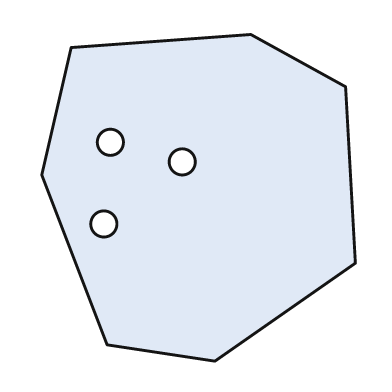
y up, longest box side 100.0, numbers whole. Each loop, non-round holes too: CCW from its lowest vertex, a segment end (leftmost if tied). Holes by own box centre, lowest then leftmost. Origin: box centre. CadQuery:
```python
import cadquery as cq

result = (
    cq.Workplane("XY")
    .moveTo(5.0, -50.0)
    .lineTo(48.0, -20.0)
    .lineTo(45.0, 34.0)
    .lineTo(16.0, 50.0)
    .lineTo(-39.0, 46.0)
    .lineTo(-48.0, 7.0)
    .lineTo(-28.0, -45.0)
    .close()
    .moveTo(-29.0, -8.0)
    .circle(4.0)
    .moveTo(-5.0, 11.0)
    .circle(4.0)
    .moveTo(-27.0, 17.0)
    .circle(4.0)
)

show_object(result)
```